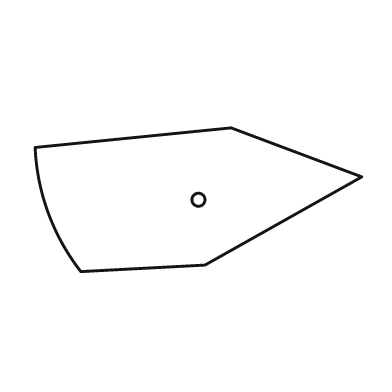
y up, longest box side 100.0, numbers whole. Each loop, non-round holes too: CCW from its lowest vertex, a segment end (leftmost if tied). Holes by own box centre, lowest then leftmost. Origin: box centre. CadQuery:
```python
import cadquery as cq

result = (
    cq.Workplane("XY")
    .moveTo(-36.0, -22.0)
    .lineTo(2.0, -20.0)
    .lineTo(50.0, 7.0)
    .lineTo(10.0, 22.0)
    .lineTo(-50.0, 16.0)
    .threePointArc((-46.0, -4.0), (-36.0, -22.0))
    .close()
    .moveTo(0.0, 0.0)
    .circle(2.0)
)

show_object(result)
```